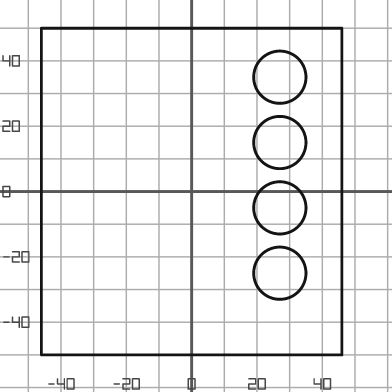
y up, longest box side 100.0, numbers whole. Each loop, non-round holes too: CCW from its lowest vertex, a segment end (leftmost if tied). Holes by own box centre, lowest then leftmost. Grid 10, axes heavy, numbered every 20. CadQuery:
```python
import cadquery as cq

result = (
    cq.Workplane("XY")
    .moveTo(-46.0, -50.0)
    .lineTo(46.0, -50.0)
    .lineTo(46.0, 50.0)
    .lineTo(-46.0, 50.0)
    .close()
    .moveTo(27.0, -25.0)
    .circle(8.0)
    .moveTo(27.0, -5.0)
    .circle(8.0)
    .moveTo(27.0, 15.0)
    .circle(8.0)
    .moveTo(27.0, 35.0)
    .circle(8.0)
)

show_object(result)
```